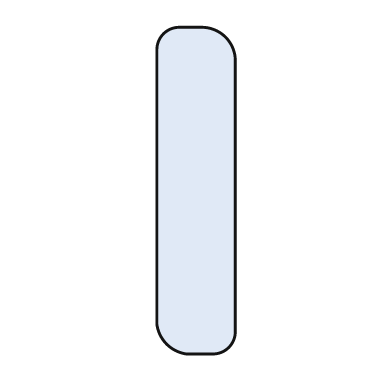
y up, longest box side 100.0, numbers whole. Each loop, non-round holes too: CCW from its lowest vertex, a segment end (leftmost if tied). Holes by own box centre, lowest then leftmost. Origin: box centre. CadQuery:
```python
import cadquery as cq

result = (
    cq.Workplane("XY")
    .moveTo(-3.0, -50.0)
    .lineTo(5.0, -50.0)
    .threePointArc((10.0, -48.0), (12.0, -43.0))
    .lineTo(12.0, 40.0)
    .threePointArc((9.0, 47.0), (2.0, 50.0))
    .lineTo(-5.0, 50.0)
    .threePointArc((-10.0, 48.0), (-12.0, 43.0))
    .lineTo(-12.0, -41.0)
    .threePointArc((-9.0, -47.0), (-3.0, -50.0))
    .close()
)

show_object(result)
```